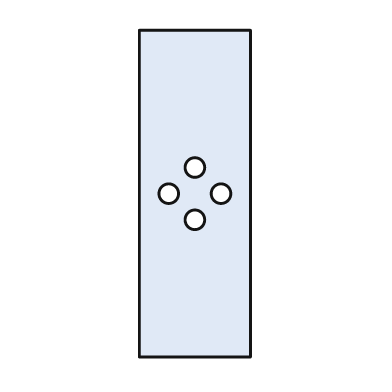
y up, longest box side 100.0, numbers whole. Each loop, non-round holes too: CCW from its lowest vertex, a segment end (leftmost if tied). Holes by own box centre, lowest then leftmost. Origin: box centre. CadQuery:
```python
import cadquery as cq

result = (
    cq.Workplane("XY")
    .moveTo(-17.0, -50.0)
    .lineTo(17.0, -50.0)
    .lineTo(17.0, 50.0)
    .lineTo(-17.0, 50.0)
    .close()
    .moveTo(0.0, -8.0)
    .circle(3.0)
    .moveTo(-8.0, 0.0)
    .circle(3.0)
    .moveTo(8.0, 0.0)
    .circle(3.0)
    .moveTo(0.0, 8.0)
    .circle(3.0)
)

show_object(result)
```